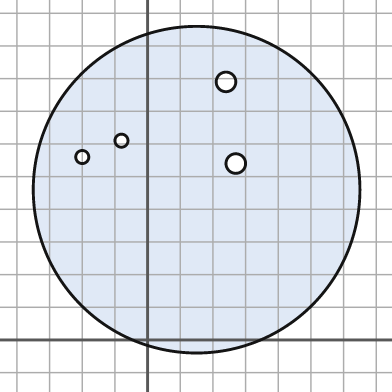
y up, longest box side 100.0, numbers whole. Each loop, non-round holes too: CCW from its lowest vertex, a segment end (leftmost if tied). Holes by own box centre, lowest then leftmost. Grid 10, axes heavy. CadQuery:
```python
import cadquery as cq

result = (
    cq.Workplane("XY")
    .moveTo(15.0, 46.0)
    .circle(50.0)
    .moveTo(27.0, 54.0)
    .circle(3.0)
    .moveTo(-20.0, 56.0)
    .circle(2.0)
    .moveTo(-8.0, 61.0)
    .circle(2.0)
    .moveTo(24.0, 79.0)
    .circle(3.0)
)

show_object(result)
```